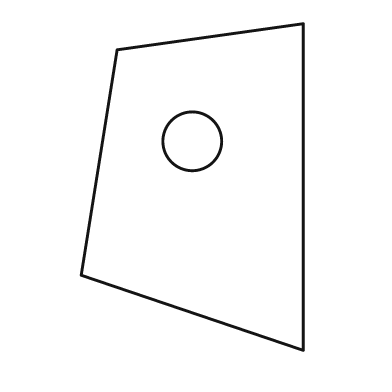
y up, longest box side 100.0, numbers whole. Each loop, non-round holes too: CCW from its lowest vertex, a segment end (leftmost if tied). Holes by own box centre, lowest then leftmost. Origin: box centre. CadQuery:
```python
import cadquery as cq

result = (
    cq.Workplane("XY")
    .moveTo(34.0, -50.0)
    .lineTo(34.0, 50.0)
    .lineTo(-23.0, 42.0)
    .lineTo(-34.0, -27.0)
    .close()
    .moveTo(0.0, 14.0)
    .circle(9.0)
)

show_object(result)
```